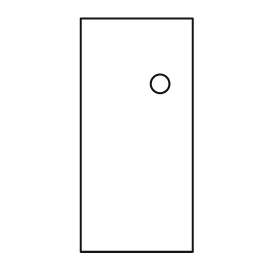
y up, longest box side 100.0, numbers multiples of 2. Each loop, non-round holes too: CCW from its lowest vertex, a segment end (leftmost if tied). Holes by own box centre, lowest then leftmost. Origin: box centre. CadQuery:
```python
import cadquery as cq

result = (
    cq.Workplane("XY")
    .moveTo(-24.0, -50.0)
    .lineTo(24.0, -50.0)
    .lineTo(24.0, 50.0)
    .lineTo(-24.0, 50.0)
    .close()
    .moveTo(10.0, 22.0)
    .circle(4.0)
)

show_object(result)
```